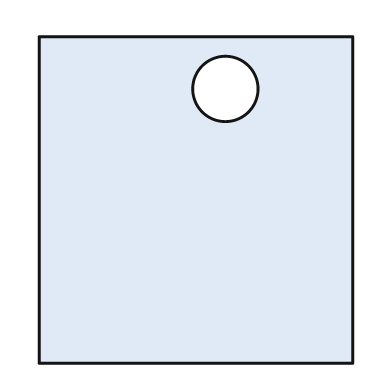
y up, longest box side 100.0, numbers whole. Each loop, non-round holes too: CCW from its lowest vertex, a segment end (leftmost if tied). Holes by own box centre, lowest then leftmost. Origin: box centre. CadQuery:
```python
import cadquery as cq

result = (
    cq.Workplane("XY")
    .moveTo(-48.0, -50.0)
    .lineTo(48.0, -50.0)
    .lineTo(48.0, 50.0)
    .lineTo(-48.0, 50.0)
    .close()
    .moveTo(9.0, 34.0)
    .circle(10.0)
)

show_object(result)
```